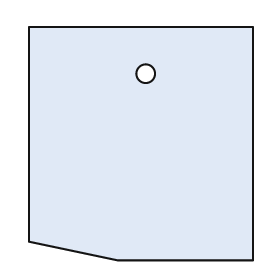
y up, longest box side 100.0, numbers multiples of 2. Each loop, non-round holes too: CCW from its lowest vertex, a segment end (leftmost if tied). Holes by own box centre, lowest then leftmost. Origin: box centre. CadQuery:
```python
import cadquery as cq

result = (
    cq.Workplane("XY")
    .moveTo(-10.0, -50.0)
    .lineTo(48.0, -50.0)
    .lineTo(48.0, 50.0)
    .lineTo(-48.0, 50.0)
    .lineTo(-48.0, -42.0)
    .close()
    .moveTo(2.0, 30.0)
    .circle(4.0)
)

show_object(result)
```